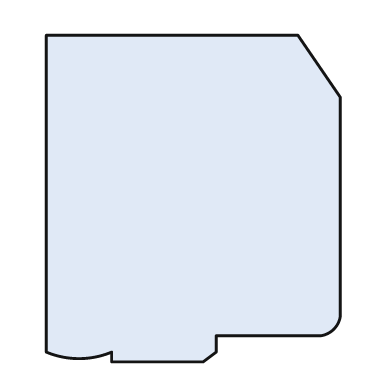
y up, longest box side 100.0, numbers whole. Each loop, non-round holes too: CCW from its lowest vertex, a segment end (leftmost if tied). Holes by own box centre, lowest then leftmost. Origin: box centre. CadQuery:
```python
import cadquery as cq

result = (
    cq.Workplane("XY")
    .moveTo(-25.0, -50.0)
    .lineTo(3.0, -50.0)
    .lineTo(7.0, -47.0)
    .lineTo(7.0, -42.0)
    .lineTo(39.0, -42.0)
    .threePointArc((43.0, -40.0), (45.0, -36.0))
    .lineTo(45.0, 31.0)
    .lineTo(32.0, 50.0)
    .lineTo(-45.0, 50.0)
    .lineTo(-45.0, -47.0)
    .threePointArc((-35.0, -49.0), (-25.0, -47.0))
    .close()
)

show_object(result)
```